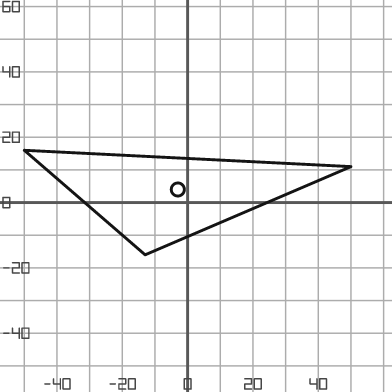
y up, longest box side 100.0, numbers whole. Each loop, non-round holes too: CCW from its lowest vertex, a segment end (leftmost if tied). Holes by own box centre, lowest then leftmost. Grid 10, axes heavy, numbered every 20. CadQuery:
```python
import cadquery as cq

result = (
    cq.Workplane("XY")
    .moveTo(-13.0, -16.0)
    .lineTo(50.0, 11.0)
    .lineTo(-50.0, 16.0)
    .close()
    .moveTo(-3.0, 4.0)
    .circle(2.0)
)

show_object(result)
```